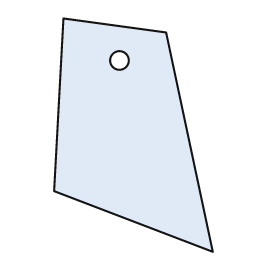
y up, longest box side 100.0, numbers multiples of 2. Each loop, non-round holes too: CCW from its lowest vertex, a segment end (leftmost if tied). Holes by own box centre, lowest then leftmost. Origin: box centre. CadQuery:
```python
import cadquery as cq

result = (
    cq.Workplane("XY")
    .moveTo(34.0, -50.0)
    .lineTo(14.0, 44.0)
    .lineTo(-30.0, 50.0)
    .lineTo(-34.0, -24.0)
    .close()
    .moveTo(-6.0, 32.0)
    .circle(4.0)
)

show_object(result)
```